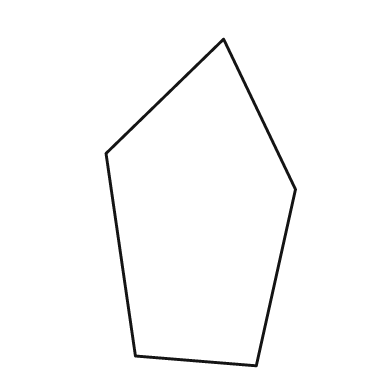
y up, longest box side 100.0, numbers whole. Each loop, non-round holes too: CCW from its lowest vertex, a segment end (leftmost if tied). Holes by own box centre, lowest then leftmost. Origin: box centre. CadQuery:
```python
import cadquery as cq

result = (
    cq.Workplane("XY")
    .moveTo(17.0, -50.0)
    .lineTo(29.0, 4.0)
    .lineTo(7.0, 50.0)
    .lineTo(-29.0, 15.0)
    .lineTo(-20.0, -47.0)
    .close()
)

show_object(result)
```